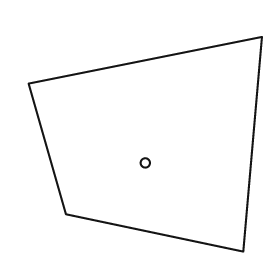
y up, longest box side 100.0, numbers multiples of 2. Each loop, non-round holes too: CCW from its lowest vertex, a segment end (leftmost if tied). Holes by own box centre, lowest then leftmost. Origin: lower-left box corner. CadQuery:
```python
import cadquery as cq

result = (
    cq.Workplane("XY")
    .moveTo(92.0, 0.0)
    .lineTo(100.0, 92.0)
    .lineTo(0.0, 72.0)
    .lineTo(16.0, 16.0)
    .close()
    .moveTo(50.0, 38.0)
    .circle(2.0)
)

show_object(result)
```